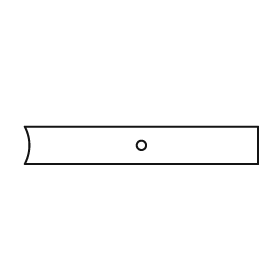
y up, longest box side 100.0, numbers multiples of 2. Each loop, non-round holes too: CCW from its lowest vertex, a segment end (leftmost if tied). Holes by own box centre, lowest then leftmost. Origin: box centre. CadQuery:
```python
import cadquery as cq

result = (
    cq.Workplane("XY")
    .moveTo(-50.0, -8.0)
    .lineTo(50.0, -8.0)
    .lineTo(50.0, 8.0)
    .lineTo(-50.0, 8.0)
    .threePointArc((-48.0, 0.0), (-50.0, -8.0))
    .close()
    .moveTo(0.0, 0.0)
    .circle(2.0)
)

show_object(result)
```